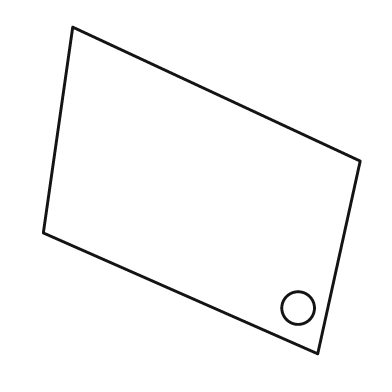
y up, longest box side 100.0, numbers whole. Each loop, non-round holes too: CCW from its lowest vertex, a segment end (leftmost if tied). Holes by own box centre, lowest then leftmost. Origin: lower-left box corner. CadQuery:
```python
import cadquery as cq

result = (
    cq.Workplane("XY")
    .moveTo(84.0, 0.0)
    .lineTo(97.0, 59.0)
    .lineTo(9.0, 100.0)
    .lineTo(0.0, 37.0)
    .close()
    .moveTo(78.0, 14.0)
    .circle(5.0)
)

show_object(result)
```